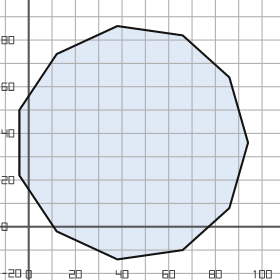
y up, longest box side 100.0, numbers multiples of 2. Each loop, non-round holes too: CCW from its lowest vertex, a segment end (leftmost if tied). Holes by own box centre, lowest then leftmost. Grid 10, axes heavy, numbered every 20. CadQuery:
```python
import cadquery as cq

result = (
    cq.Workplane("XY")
    .moveTo(38.0, -14.0)
    .lineTo(66.0, -10.0)
    .lineTo(86.0, 8.0)
    .lineTo(94.0, 36.0)
    .lineTo(86.0, 64.0)
    .lineTo(66.0, 82.0)
    .lineTo(38.0, 86.0)
    .lineTo(12.0, 74.0)
    .lineTo(-4.0, 50.0)
    .lineTo(-4.0, 22.0)
    .lineTo(12.0, -2.0)
    .close()
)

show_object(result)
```